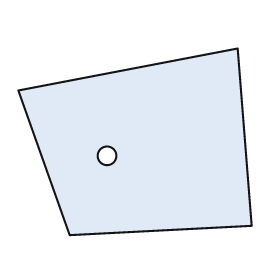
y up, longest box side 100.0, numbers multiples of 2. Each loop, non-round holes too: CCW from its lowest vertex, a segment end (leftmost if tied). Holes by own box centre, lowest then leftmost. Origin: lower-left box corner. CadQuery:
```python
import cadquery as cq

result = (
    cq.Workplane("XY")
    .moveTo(22.0, 0.0)
    .lineTo(100.0, 4.0)
    .lineTo(94.0, 80.0)
    .lineTo(0.0, 62.0)
    .close()
    .moveTo(38.0, 34.0)
    .circle(4.0)
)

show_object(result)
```